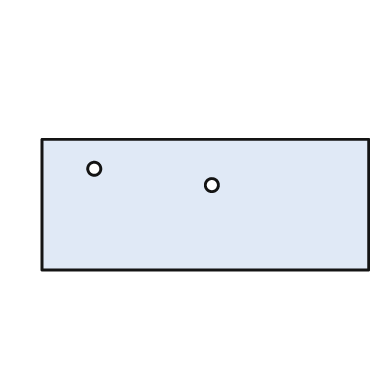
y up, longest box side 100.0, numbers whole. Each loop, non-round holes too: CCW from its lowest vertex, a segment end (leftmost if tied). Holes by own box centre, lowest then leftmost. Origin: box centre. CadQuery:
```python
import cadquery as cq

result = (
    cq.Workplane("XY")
    .moveTo(-50.0, -20.0)
    .lineTo(50.0, -20.0)
    .lineTo(50.0, 20.0)
    .lineTo(-50.0, 20.0)
    .close()
    .moveTo(2.0, 6.0)
    .circle(2.0)
    .moveTo(-34.0, 11.0)
    .circle(2.0)
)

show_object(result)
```